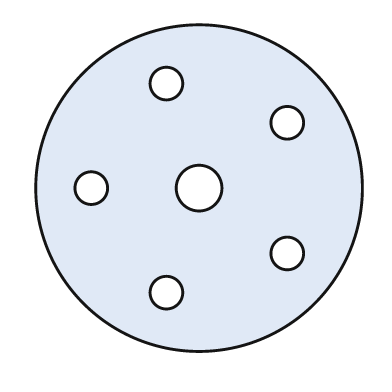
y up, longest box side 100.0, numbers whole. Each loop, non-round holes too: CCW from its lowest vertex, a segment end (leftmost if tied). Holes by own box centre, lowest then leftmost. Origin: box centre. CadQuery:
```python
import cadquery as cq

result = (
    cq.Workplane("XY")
    .moveTo(0.0, 0.0)
    .circle(50.0)
    .moveTo(-10.0, -32.0)
    .circle(5.0)
    .moveTo(27.0, -20.0)
    .circle(5.0)
    .moveTo(-33.0, 0.0)
    .circle(5.0)
    .moveTo(0.0, 0.0)
    .circle(7.0)
    .moveTo(27.0, 20.0)
    .circle(5.0)
    .moveTo(-10.0, 32.0)
    .circle(5.0)
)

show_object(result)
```